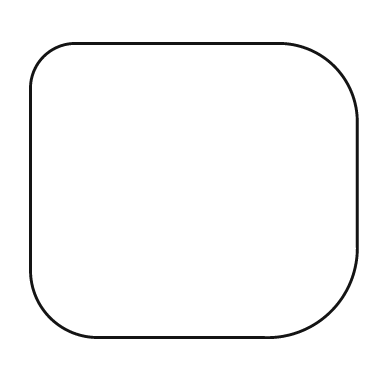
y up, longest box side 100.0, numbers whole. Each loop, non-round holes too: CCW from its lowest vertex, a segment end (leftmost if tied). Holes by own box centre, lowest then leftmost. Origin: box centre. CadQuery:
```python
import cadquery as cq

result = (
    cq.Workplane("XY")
    .moveTo(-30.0, -45.0)
    .lineTo(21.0, -45.0)
    .threePointArc((42.0, -37.0), (50.0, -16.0))
    .lineTo(50.0, 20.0)
    .threePointArc((43.0, 38.0), (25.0, 45.0))
    .lineTo(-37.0, 45.0)
    .threePointArc((-46.0, 41.0), (-50.0, 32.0))
    .lineTo(-50.0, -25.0)
    .threePointArc((-44.0, -39.0), (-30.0, -45.0))
    .close()
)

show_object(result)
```